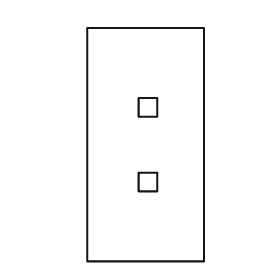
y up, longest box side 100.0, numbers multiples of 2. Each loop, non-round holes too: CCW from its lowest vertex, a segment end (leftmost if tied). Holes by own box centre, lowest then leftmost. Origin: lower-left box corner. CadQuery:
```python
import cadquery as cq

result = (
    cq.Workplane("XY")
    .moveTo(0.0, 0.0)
    .lineTo(50.0, 0.0)
    .lineTo(50.0, 100.0)
    .lineTo(0.0, 100.0)
    .close()
    .moveTo(22.0, 30.0)
    .lineTo(30.0, 30.0)
    .lineTo(30.0, 38.0)
    .lineTo(22.0, 38.0)
    .close()
    .moveTo(22.0, 62.0)
    .lineTo(30.0, 62.0)
    .lineTo(30.0, 70.0)
    .lineTo(22.0, 70.0)
    .close()
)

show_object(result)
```